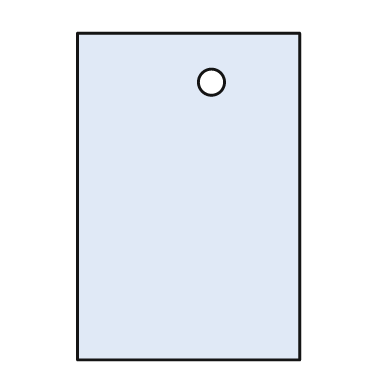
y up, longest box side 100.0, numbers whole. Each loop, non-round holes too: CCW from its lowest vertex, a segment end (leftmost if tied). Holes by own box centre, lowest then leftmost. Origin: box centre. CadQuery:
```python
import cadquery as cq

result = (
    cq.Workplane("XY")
    .moveTo(-34.0, -50.0)
    .lineTo(34.0, -50.0)
    .lineTo(34.0, 50.0)
    .lineTo(-34.0, 50.0)
    .close()
    .moveTo(7.0, 35.0)
    .circle(4.0)
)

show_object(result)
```